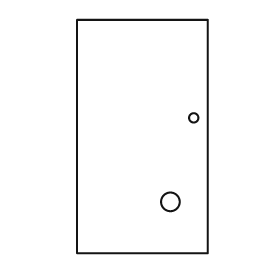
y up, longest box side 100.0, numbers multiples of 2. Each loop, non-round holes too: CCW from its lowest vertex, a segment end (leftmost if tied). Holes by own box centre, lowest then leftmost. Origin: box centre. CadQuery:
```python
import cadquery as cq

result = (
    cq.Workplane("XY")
    .moveTo(-28.0, -50.0)
    .lineTo(28.0, -50.0)
    .lineTo(28.0, 50.0)
    .lineTo(-28.0, 50.0)
    .close()
    .moveTo(12.0, -28.0)
    .circle(4.0)
    .moveTo(22.0, 8.0)
    .circle(2.0)
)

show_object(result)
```